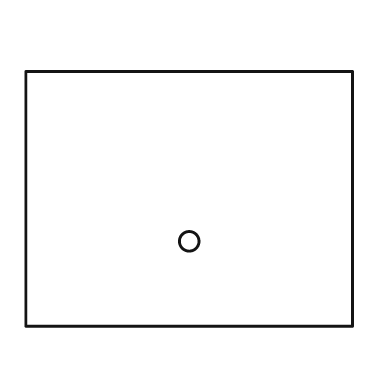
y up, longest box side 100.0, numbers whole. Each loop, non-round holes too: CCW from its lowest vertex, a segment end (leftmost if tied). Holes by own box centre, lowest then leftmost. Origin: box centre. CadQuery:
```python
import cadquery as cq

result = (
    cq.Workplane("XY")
    .moveTo(-50.0, -39.0)
    .lineTo(50.0, -39.0)
    .lineTo(50.0, 39.0)
    .lineTo(-50.0, 39.0)
    .close()
    .moveTo(0.0, -13.0)
    .circle(3.0)
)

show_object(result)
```